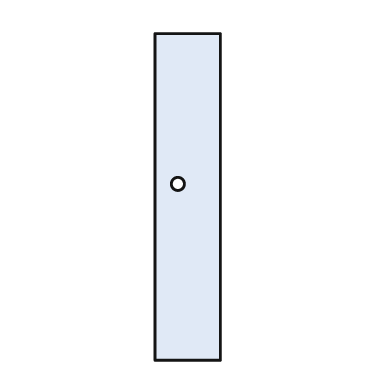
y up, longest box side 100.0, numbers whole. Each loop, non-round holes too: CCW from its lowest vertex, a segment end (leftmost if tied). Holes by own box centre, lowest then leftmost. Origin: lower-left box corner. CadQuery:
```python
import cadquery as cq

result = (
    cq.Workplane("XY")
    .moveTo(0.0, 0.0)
    .lineTo(20.0, 0.0)
    .lineTo(20.0, 100.0)
    .lineTo(0.0, 100.0)
    .close()
    .moveTo(7.0, 54.0)
    .circle(2.0)
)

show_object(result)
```